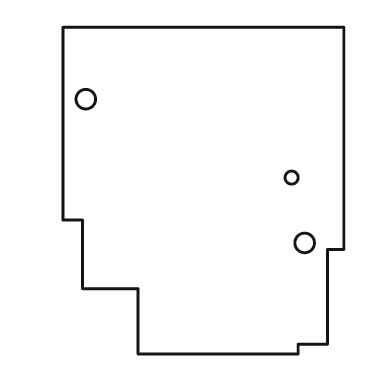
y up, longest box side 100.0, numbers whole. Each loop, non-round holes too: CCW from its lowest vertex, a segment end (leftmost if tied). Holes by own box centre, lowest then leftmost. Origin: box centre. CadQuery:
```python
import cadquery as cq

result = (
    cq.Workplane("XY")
    .moveTo(-20.0, -50.0)
    .lineTo(29.0, -50.0)
    .lineTo(29.0, -47.0)
    .lineTo(38.0, -47.0)
    .lineTo(38.0, -18.0)
    .lineTo(43.0, -18.0)
    .lineTo(43.0, 50.0)
    .lineTo(-43.0, 50.0)
    .lineTo(-43.0, -9.0)
    .lineTo(-37.0, -9.0)
    .lineTo(-37.0, -30.0)
    .lineTo(-20.0, -30.0)
    .close()
    .moveTo(31.0, -16.0)
    .circle(3.0)
    .moveTo(27.0, 4.0)
    .circle(2.0)
    .moveTo(-36.0, 28.0)
    .circle(3.0)
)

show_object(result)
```